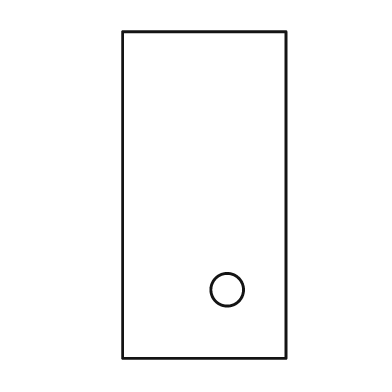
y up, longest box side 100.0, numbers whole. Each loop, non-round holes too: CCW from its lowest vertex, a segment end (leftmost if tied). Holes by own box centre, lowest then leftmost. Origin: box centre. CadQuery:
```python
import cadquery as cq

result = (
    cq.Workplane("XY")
    .moveTo(-25.0, -50.0)
    .lineTo(25.0, -50.0)
    .lineTo(25.0, 50.0)
    .lineTo(-25.0, 50.0)
    .close()
    .moveTo(7.0, -29.0)
    .circle(5.0)
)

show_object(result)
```